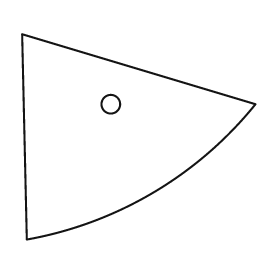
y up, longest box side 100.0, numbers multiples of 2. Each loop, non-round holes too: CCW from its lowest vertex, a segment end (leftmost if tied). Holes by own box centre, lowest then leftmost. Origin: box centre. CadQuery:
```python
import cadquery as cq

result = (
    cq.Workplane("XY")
    .moveTo(-48.0, -44.0)
    .threePointArc((6.0, -24.0), (50.0, 14.0))
    .lineTo(-50.0, 44.0)
    .close()
    .moveTo(-12.0, 14.0)
    .circle(4.0)
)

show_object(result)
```